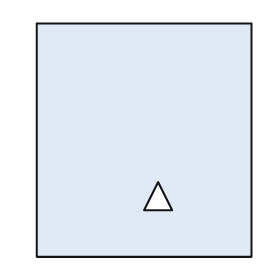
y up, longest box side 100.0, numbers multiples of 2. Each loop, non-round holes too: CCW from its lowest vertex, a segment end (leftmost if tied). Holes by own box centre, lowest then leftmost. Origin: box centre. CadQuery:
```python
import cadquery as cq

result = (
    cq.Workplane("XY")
    .moveTo(-46.0, -50.0)
    .lineTo(46.0, -50.0)
    .lineTo(46.0, 50.0)
    .lineTo(-46.0, 50.0)
    .close()
    .moveTo(0.0, -30.0)
    .lineTo(12.0, -30.0)
    .lineTo(6.0, -18.0)
    .close()
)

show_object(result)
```